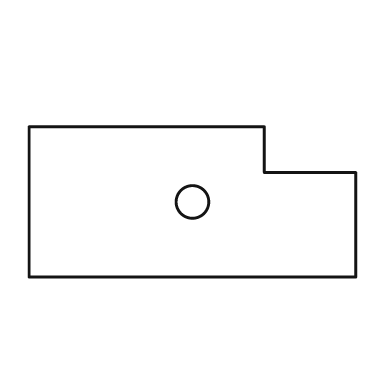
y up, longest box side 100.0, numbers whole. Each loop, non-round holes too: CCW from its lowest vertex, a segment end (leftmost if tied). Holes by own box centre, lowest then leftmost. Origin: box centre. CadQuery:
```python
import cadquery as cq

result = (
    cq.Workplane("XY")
    .moveTo(-50.0, -23.0)
    .lineTo(50.0, -23.0)
    .lineTo(50.0, 9.0)
    .lineTo(22.0, 9.0)
    .lineTo(22.0, 23.0)
    .lineTo(-50.0, 23.0)
    .close()
    .moveTo(0.0, 0.0)
    .circle(5.0)
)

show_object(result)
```